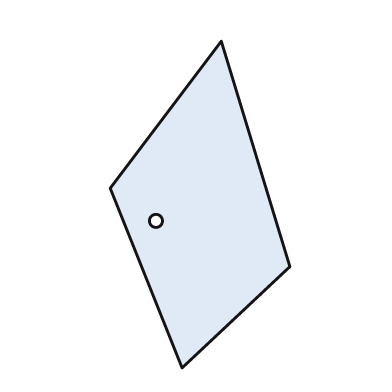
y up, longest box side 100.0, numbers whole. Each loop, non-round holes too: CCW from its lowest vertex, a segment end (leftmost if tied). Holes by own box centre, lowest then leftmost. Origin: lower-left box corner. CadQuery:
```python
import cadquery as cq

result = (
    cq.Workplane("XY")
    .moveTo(22.0, 0.0)
    .lineTo(55.0, 31.0)
    .lineTo(34.0, 100.0)
    .lineTo(0.0, 55.0)
    .close()
    .moveTo(14.0, 45.0)
    .circle(2.0)
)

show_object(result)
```